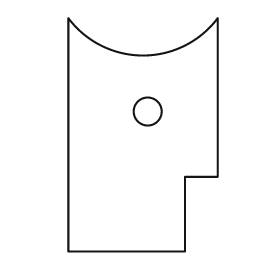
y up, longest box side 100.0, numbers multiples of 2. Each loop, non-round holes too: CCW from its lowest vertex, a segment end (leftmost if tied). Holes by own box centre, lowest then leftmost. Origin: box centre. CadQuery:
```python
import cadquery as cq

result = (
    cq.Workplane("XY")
    .moveTo(-32.0, -50.0)
    .lineTo(18.0, -50.0)
    .lineTo(18.0, -18.0)
    .lineTo(32.0, -18.0)
    .lineTo(32.0, 50.0)
    .threePointArc((0.0, 34.0), (-32.0, 50.0))
    .close()
    .moveTo(2.0, 10.0)
    .circle(6.0)
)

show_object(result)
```